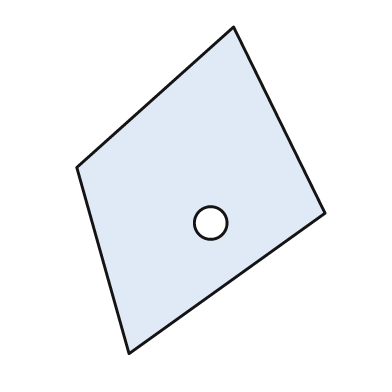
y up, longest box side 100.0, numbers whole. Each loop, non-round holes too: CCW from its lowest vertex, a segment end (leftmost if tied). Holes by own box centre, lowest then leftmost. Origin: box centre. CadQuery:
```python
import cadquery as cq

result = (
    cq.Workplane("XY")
    .moveTo(-22.0, -50.0)
    .lineTo(38.0, -7.0)
    .lineTo(10.0, 50.0)
    .lineTo(-38.0, 7.0)
    .close()
    .moveTo(3.0, -10.0)
    .circle(5.0)
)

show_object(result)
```